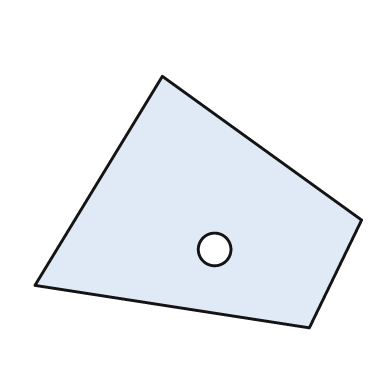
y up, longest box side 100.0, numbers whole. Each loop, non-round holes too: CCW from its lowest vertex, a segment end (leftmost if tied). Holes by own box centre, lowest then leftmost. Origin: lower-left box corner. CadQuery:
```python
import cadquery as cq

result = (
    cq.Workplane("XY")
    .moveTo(84.0, 0.0)
    .lineTo(100.0, 33.0)
    .lineTo(39.0, 77.0)
    .lineTo(0.0, 13.0)
    .close()
    .moveTo(55.0, 24.0)
    .circle(5.0)
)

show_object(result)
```